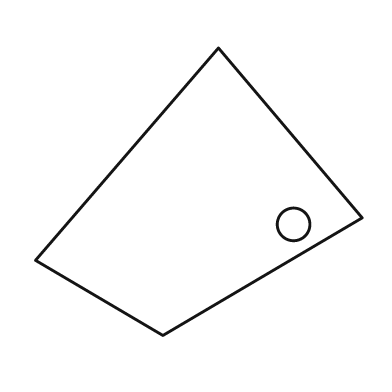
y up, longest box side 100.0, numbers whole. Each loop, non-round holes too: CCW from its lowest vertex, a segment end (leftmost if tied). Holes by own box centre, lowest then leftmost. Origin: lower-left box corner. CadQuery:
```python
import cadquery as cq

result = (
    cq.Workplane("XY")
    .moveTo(39.0, 0.0)
    .lineTo(100.0, 36.0)
    .lineTo(56.0, 88.0)
    .lineTo(0.0, 23.0)
    .close()
    .moveTo(79.0, 34.0)
    .circle(5.0)
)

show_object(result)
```